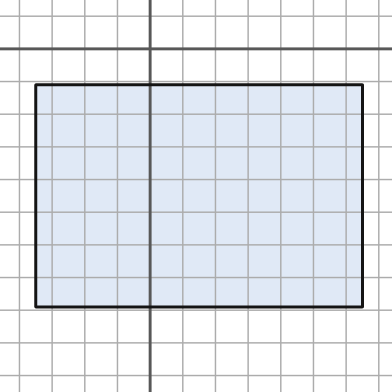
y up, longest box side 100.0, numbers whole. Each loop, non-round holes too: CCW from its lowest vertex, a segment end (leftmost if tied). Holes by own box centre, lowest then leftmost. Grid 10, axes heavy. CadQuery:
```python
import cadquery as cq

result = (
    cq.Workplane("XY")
    .moveTo(-35.0, -79.0)
    .lineTo(65.0, -79.0)
    .lineTo(65.0, -11.0)
    .lineTo(-35.0, -11.0)
    .close()
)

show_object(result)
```